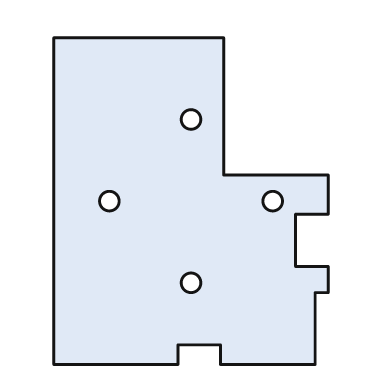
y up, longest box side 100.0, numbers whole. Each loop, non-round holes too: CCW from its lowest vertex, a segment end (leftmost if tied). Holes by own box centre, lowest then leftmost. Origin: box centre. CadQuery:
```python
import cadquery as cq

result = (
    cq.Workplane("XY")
    .moveTo(-42.0, -50.0)
    .lineTo(-4.0, -50.0)
    .lineTo(-4.0, -44.0)
    .lineTo(9.0, -44.0)
    .lineTo(9.0, -50.0)
    .lineTo(38.0, -50.0)
    .lineTo(38.0, -28.0)
    .lineTo(42.0, -28.0)
    .lineTo(42.0, -20.0)
    .lineTo(32.0, -20.0)
    .lineTo(32.0, -4.0)
    .lineTo(42.0, -4.0)
    .lineTo(42.0, 8.0)
    .lineTo(10.0, 8.0)
    .lineTo(10.0, 50.0)
    .lineTo(-42.0, 50.0)
    .close()
    .moveTo(0.0, -25.0)
    .circle(3.0)
    .moveTo(-25.0, 0.0)
    .circle(3.0)
    .moveTo(25.0, 0.0)
    .circle(3.0)
    .moveTo(0.0, 25.0)
    .circle(3.0)
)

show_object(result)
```